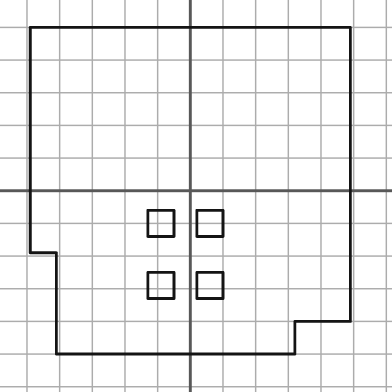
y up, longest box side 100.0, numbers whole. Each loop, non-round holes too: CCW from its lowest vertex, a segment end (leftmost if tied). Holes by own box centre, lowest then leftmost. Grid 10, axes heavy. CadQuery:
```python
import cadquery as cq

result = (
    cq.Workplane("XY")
    .moveTo(-41.0, -50.0)
    .lineTo(32.0, -50.0)
    .lineTo(32.0, -40.0)
    .lineTo(49.0, -40.0)
    .lineTo(49.0, 50.0)
    .lineTo(-49.0, 50.0)
    .lineTo(-49.0, -19.0)
    .lineTo(-41.0, -19.0)
    .close()
    .moveTo(-13.0, -33.0)
    .lineTo(-5.0, -33.0)
    .lineTo(-5.0, -25.0)
    .lineTo(-13.0, -25.0)
    .close()
    .moveTo(2.0, -33.0)
    .lineTo(10.0, -33.0)
    .lineTo(10.0, -25.0)
    .lineTo(2.0, -25.0)
    .close()
    .moveTo(-13.0, -14.0)
    .lineTo(-5.0, -14.0)
    .lineTo(-5.0, -6.0)
    .lineTo(-13.0, -6.0)
    .close()
    .moveTo(2.0, -14.0)
    .lineTo(10.0, -14.0)
    .lineTo(10.0, -6.0)
    .lineTo(2.0, -6.0)
    .close()
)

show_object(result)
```